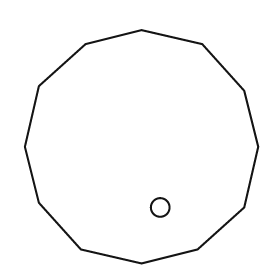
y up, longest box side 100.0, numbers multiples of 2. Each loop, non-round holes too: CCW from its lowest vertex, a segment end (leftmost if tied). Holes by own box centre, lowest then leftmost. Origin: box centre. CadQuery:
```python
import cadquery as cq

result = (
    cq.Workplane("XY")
    .moveTo(0.0, -50.0)
    .lineTo(24.0, -44.0)
    .lineTo(44.0, -26.0)
    .lineTo(50.0, 0.0)
    .lineTo(44.0, 24.0)
    .lineTo(26.0, 44.0)
    .lineTo(0.0, 50.0)
    .lineTo(-24.0, 44.0)
    .lineTo(-44.0, 26.0)
    .lineTo(-50.0, 0.0)
    .lineTo(-44.0, -24.0)
    .lineTo(-26.0, -44.0)
    .close()
    .moveTo(8.0, -26.0)
    .circle(4.0)
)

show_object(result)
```